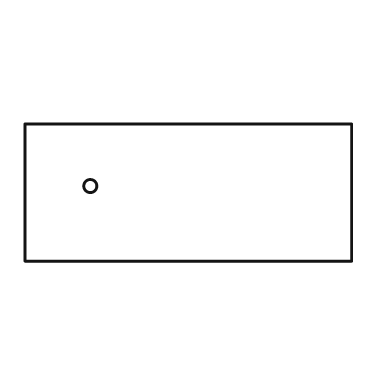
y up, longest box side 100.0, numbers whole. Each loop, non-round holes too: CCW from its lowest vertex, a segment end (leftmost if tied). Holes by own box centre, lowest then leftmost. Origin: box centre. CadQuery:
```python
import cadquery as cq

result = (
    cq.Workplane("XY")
    .moveTo(-50.0, -21.0)
    .lineTo(50.0, -21.0)
    .lineTo(50.0, 21.0)
    .lineTo(-50.0, 21.0)
    .close()
    .moveTo(-30.0, 2.0)
    .circle(2.0)
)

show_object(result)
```